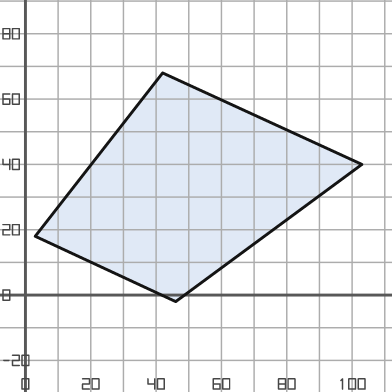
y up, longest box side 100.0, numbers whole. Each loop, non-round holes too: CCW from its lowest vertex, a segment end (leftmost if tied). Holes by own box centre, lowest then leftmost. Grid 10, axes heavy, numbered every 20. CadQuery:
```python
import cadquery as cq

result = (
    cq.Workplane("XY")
    .moveTo(46.0, -2.0)
    .lineTo(103.0, 40.0)
    .lineTo(42.0, 68.0)
    .lineTo(3.0, 18.0)
    .close()
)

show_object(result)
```